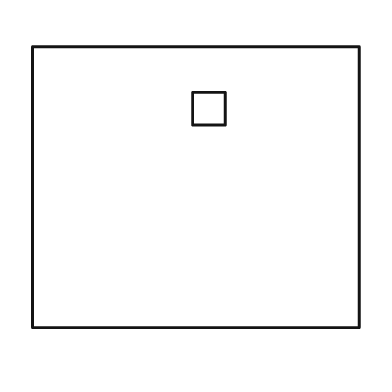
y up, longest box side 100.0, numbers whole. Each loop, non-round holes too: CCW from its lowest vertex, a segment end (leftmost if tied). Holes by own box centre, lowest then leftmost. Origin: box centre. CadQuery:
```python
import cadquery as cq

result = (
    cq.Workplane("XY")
    .moveTo(-50.0, -43.0)
    .lineTo(50.0, -43.0)
    .lineTo(50.0, 43.0)
    .lineTo(-50.0, 43.0)
    .close()
    .moveTo(-1.0, 19.0)
    .lineTo(9.0, 19.0)
    .lineTo(9.0, 29.0)
    .lineTo(-1.0, 29.0)
    .close()
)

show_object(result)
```